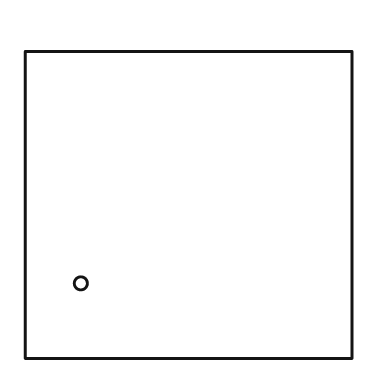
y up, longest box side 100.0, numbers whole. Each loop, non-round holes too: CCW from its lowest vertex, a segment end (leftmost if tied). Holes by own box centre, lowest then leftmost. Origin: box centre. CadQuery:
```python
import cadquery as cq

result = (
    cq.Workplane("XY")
    .moveTo(-50.0, -47.0)
    .lineTo(50.0, -47.0)
    .lineTo(50.0, 47.0)
    .lineTo(-50.0, 47.0)
    .close()
    .moveTo(-33.0, -24.0)
    .circle(2.0)
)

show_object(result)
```